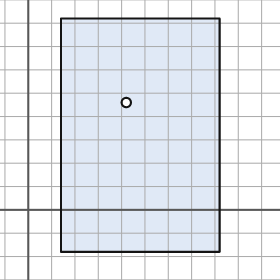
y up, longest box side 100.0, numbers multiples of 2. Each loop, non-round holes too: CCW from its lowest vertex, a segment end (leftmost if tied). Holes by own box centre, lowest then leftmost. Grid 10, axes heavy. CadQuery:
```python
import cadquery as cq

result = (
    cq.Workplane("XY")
    .moveTo(14.0, -18.0)
    .lineTo(82.0, -18.0)
    .lineTo(82.0, 82.0)
    .lineTo(14.0, 82.0)
    .close()
    .moveTo(42.0, 46.0)
    .circle(2.0)
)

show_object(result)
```